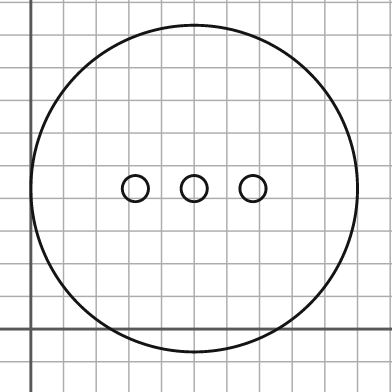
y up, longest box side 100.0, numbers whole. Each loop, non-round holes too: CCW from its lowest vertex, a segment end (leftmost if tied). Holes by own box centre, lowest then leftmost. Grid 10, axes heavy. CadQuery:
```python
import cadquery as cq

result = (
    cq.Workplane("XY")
    .moveTo(50.0, 43.0)
    .circle(50.0)
    .moveTo(32.0, 43.0)
    .circle(4.0)
    .moveTo(50.0, 43.0)
    .circle(4.0)
    .moveTo(68.0, 43.0)
    .circle(4.0)
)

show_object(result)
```